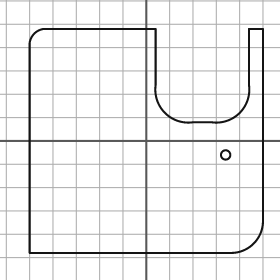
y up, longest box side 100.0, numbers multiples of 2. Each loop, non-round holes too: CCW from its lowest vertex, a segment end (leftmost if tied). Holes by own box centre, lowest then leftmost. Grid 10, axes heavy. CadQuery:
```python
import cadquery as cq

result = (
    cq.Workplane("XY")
    .moveTo(-50.0, -48.0)
    .lineTo(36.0, -48.0)
    .threePointArc((46.0, -44.0), (50.0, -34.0))
    .lineTo(50.0, 48.0)
    .lineTo(44.0, 48.0)
    .lineTo(44.0, 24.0)
    .threePointArc((40.0, 12.0), (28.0, 8.0))
    .lineTo(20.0, 8.0)
    .threePointArc((8.0, 12.0), (4.0, 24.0))
    .lineTo(4.0, 48.0)
    .lineTo(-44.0, 48.0)
    .threePointArc((-48.0, 46.0), (-50.0, 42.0))
    .close()
    .moveTo(34.0, -6.0)
    .circle(2.0)
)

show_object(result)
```